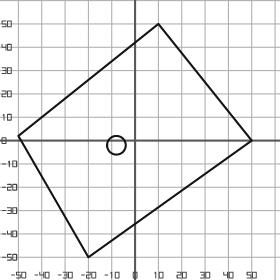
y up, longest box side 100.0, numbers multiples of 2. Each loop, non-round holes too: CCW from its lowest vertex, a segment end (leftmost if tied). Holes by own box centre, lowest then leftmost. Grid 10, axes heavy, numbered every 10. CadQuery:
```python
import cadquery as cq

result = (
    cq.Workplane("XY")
    .moveTo(-20.0, -50.0)
    .lineTo(50.0, 0.0)
    .lineTo(10.0, 50.0)
    .lineTo(-50.0, 2.0)
    .close()
    .moveTo(-8.0, -2.0)
    .circle(4.0)
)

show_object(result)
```